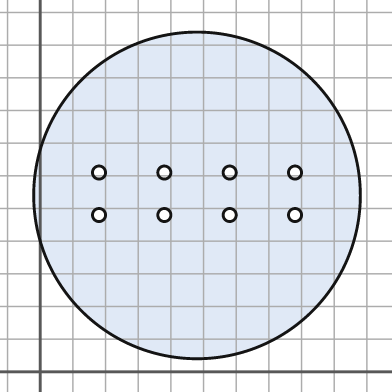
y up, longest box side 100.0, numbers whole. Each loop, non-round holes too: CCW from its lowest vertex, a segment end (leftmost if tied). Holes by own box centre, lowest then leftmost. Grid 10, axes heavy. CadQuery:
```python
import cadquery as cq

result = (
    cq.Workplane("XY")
    .moveTo(48.0, 54.0)
    .circle(50.0)
    .moveTo(18.0, 48.0)
    .circle(2.0)
    .moveTo(38.0, 48.0)
    .circle(2.0)
    .moveTo(58.0, 48.0)
    .circle(2.0)
    .moveTo(78.0, 48.0)
    .circle(2.0)
    .moveTo(18.0, 61.0)
    .circle(2.0)
    .moveTo(38.0, 61.0)
    .circle(2.0)
    .moveTo(58.0, 61.0)
    .circle(2.0)
    .moveTo(78.0, 61.0)
    .circle(2.0)
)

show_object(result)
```